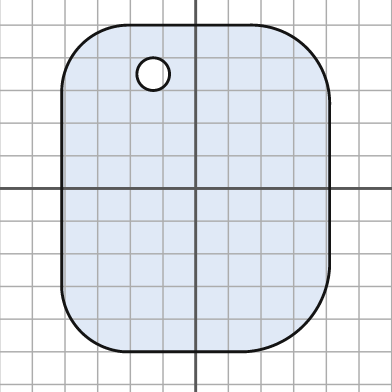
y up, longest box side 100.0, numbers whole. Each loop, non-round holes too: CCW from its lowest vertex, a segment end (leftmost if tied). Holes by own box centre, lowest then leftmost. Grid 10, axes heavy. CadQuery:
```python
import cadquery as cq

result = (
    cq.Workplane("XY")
    .moveTo(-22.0, -50.0)
    .lineTo(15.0, -50.0)
    .threePointArc((33.0, -42.0), (41.0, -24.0))
    .lineTo(41.0, 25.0)
    .threePointArc((34.0, 43.0), (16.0, 50.0))
    .lineTo(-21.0, 50.0)
    .threePointArc((-35.0, 44.0), (-41.0, 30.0))
    .lineTo(-41.0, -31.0)
    .threePointArc((-35.0, -44.0), (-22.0, -50.0))
    .close()
    .moveTo(-13.0, 35.0)
    .circle(5.0)
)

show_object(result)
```